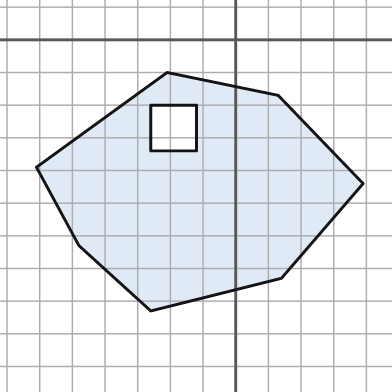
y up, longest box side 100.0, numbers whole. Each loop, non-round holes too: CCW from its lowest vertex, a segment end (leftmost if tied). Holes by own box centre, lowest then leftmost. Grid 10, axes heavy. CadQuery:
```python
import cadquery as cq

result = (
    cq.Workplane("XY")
    .moveTo(-26.0, -83.0)
    .lineTo(14.0, -73.0)
    .lineTo(39.0, -44.0)
    .lineTo(13.0, -17.0)
    .lineTo(-21.0, -10.0)
    .lineTo(-61.0, -39.0)
    .lineTo(-48.0, -63.0)
    .close()
    .moveTo(-26.0, -34.0)
    .lineTo(-12.0, -34.0)
    .lineTo(-12.0, -20.0)
    .lineTo(-26.0, -20.0)
    .close()
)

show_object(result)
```